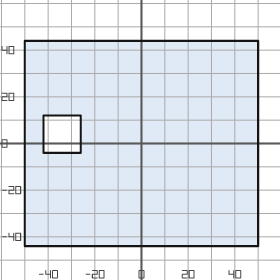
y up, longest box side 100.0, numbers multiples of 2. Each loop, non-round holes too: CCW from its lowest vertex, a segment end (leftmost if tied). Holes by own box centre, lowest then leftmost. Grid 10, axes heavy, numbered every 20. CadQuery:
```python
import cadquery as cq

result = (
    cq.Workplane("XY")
    .moveTo(-50.0, -44.0)
    .lineTo(50.0, -44.0)
    .lineTo(50.0, 44.0)
    .lineTo(-50.0, 44.0)
    .close()
    .moveTo(-42.0, -4.0)
    .lineTo(-26.0, -4.0)
    .lineTo(-26.0, 12.0)
    .lineTo(-42.0, 12.0)
    .close()
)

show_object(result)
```